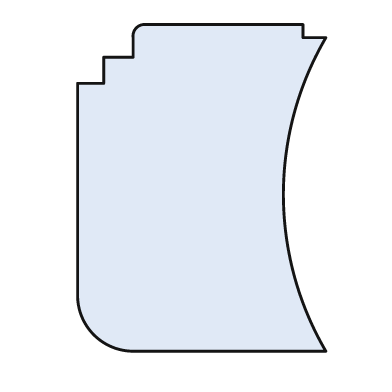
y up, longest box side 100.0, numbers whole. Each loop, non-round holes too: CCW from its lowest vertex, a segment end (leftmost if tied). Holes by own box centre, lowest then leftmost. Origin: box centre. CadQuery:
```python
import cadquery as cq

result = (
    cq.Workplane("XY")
    .moveTo(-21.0, -50.0)
    .lineTo(38.0, -50.0)
    .threePointArc((25.0, -2.0), (38.0, 46.0))
    .lineTo(31.0, 46.0)
    .lineTo(31.0, 50.0)
    .lineTo(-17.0, 50.0)
    .threePointArc((-20.0, 49.0), (-21.0, 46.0))
    .lineTo(-21.0, 40.0)
    .lineTo(-30.0, 40.0)
    .lineTo(-30.0, 32.0)
    .lineTo(-38.0, 32.0)
    .lineTo(-38.0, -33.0)
    .threePointArc((-33.0, -45.0), (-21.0, -50.0))
    .close()
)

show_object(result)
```